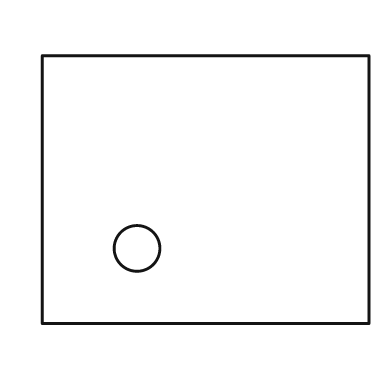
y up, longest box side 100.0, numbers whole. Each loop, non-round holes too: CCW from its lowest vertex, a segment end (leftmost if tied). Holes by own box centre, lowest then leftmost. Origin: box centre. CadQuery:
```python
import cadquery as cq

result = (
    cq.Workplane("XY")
    .moveTo(-50.0, -41.0)
    .lineTo(50.0, -41.0)
    .lineTo(50.0, 41.0)
    .lineTo(-50.0, 41.0)
    .close()
    .moveTo(-21.0, -18.0)
    .circle(7.0)
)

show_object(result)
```